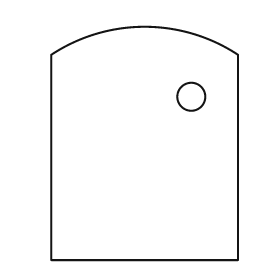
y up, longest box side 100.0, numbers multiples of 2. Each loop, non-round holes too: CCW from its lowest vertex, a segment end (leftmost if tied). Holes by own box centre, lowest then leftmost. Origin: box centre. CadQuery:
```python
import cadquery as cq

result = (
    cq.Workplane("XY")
    .moveTo(-40.0, -50.0)
    .lineTo(40.0, -50.0)
    .lineTo(40.0, 38.0)
    .threePointArc((0.0, 50.0), (-40.0, 38.0))
    .close()
    .moveTo(20.0, 20.0)
    .circle(6.0)
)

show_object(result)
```